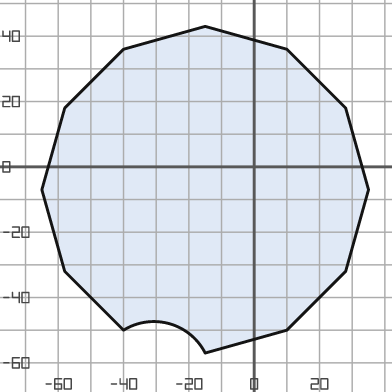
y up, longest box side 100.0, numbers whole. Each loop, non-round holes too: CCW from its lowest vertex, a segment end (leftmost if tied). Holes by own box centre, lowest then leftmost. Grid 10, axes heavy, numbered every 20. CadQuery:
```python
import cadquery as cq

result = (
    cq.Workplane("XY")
    .moveTo(-15.0, -57.0)
    .lineTo(10.0, -50.0)
    .lineTo(28.0, -32.0)
    .lineTo(35.0, -7.0)
    .lineTo(28.0, 18.0)
    .lineTo(10.0, 36.0)
    .lineTo(-15.0, 43.0)
    .lineTo(-40.0, 36.0)
    .lineTo(-58.0, 18.0)
    .lineTo(-65.0, -7.0)
    .lineTo(-58.0, -32.0)
    .lineTo(-40.0, -50.0)
    .threePointArc((-26.0, -48.0), (-15.0, -57.0))
    .close()
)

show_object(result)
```